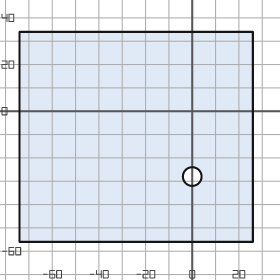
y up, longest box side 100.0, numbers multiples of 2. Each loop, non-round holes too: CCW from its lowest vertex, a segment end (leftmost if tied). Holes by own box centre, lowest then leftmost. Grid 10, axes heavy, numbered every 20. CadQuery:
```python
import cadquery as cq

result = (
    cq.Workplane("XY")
    .moveTo(-74.0, -56.0)
    .lineTo(26.0, -56.0)
    .lineTo(26.0, 34.0)
    .lineTo(-74.0, 34.0)
    .close()
    .moveTo(0.0, -28.0)
    .circle(4.0)
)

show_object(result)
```